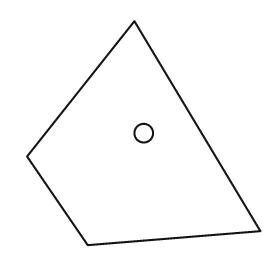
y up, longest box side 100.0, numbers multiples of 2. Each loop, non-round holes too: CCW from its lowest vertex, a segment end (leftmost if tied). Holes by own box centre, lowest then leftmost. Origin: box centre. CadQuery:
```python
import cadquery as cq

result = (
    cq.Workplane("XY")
    .moveTo(-24.0, -48.0)
    .lineTo(50.0, -42.0)
    .lineTo(-4.0, 48.0)
    .lineTo(-50.0, -10.0)
    .close()
    .moveTo(0.0, 0.0)
    .circle(4.0)
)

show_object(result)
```